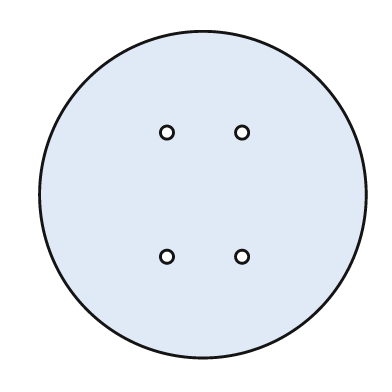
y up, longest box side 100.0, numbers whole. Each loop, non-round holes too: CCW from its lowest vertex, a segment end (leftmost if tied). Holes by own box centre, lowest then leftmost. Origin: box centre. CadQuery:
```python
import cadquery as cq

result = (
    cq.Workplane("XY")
    .moveTo(0.0, 0.0)
    .circle(50.0)
    .moveTo(-11.0, -19.0)
    .circle(2.0)
    .moveTo(12.0, -19.0)
    .circle(2.0)
    .moveTo(-11.0, 19.0)
    .circle(2.0)
    .moveTo(12.0, 19.0)
    .circle(2.0)
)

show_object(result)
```